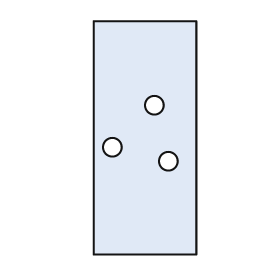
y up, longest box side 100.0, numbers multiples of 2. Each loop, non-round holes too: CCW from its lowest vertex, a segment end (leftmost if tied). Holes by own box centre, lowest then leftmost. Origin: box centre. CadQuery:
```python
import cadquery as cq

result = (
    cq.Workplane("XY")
    .moveTo(-22.0, -50.0)
    .lineTo(22.0, -50.0)
    .lineTo(22.0, 50.0)
    .lineTo(-22.0, 50.0)
    .close()
    .moveTo(10.0, -10.0)
    .circle(4.0)
    .moveTo(-14.0, -4.0)
    .circle(4.0)
    .moveTo(4.0, 14.0)
    .circle(4.0)
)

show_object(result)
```